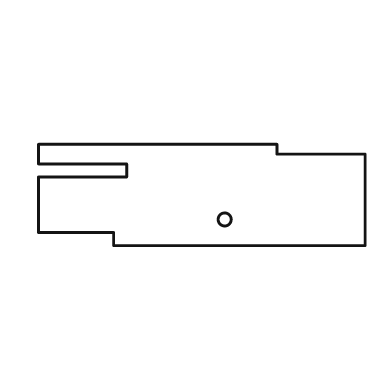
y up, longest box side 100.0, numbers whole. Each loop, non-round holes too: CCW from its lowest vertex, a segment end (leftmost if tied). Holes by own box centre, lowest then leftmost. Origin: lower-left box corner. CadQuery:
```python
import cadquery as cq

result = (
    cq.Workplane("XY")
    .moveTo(23.0, 0.0)
    .lineTo(100.0, 0.0)
    .lineTo(100.0, 28.0)
    .lineTo(73.0, 28.0)
    .lineTo(73.0, 31.0)
    .lineTo(0.0, 31.0)
    .lineTo(0.0, 25.0)
    .lineTo(27.0, 25.0)
    .lineTo(27.0, 21.0)
    .lineTo(0.0, 21.0)
    .lineTo(0.0, 4.0)
    .lineTo(23.0, 4.0)
    .close()
    .moveTo(57.0, 8.0)
    .circle(2.0)
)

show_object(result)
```